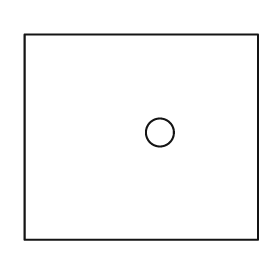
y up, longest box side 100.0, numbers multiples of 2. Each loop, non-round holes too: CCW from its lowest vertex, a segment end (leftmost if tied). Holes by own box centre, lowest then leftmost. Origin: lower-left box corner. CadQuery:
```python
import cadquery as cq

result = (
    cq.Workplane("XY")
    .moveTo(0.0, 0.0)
    .lineTo(100.0, 0.0)
    .lineTo(100.0, 88.0)
    .lineTo(0.0, 88.0)
    .close()
    .moveTo(58.0, 46.0)
    .circle(6.0)
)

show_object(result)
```